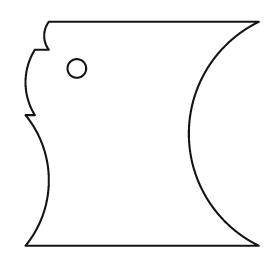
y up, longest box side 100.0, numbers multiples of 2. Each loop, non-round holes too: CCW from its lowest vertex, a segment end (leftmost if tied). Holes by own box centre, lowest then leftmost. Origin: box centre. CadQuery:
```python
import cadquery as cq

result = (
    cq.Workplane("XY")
    .moveTo(-50.0, -48.0)
    .lineTo(50.0, -48.0)
    .threePointArc((20.0, 0.0), (50.0, 48.0))
    .lineTo(-40.0, 48.0)
    .threePointArc((-42.0, 42.0), (-40.0, 36.0))
    .lineTo(-46.0, 36.0)
    .threePointArc((-50.0, 22.0), (-46.0, 8.0))
    .lineTo(-50.0, 8.0)
    .threePointArc((-40.0, -20.0), (-50.0, -48.0))
    .close()
    .moveTo(-28.0, 28.0)
    .circle(4.0)
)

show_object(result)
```